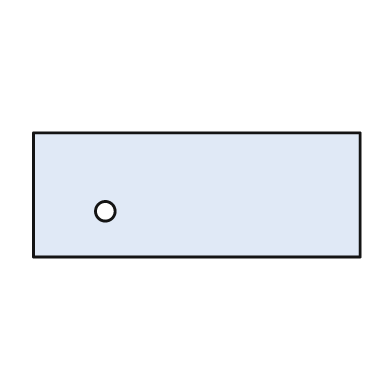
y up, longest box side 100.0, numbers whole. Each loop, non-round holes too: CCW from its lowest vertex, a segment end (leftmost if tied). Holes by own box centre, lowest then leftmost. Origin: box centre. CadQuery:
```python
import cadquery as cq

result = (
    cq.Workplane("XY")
    .moveTo(-50.0, -19.0)
    .lineTo(50.0, -19.0)
    .lineTo(50.0, 19.0)
    .lineTo(-50.0, 19.0)
    .close()
    .moveTo(-28.0, -5.0)
    .circle(3.0)
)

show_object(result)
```